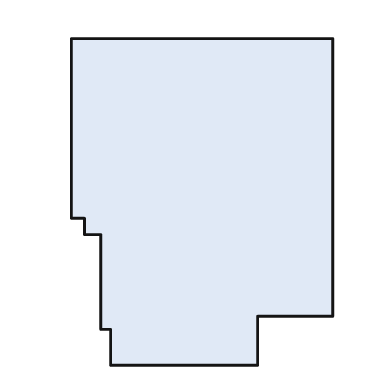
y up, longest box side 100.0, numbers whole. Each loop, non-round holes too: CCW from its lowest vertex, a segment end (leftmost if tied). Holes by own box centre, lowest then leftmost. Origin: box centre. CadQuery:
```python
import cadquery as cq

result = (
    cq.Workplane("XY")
    .moveTo(-28.0, -50.0)
    .lineTo(17.0, -50.0)
    .lineTo(17.0, -35.0)
    .lineTo(40.0, -35.0)
    .lineTo(40.0, 50.0)
    .lineTo(-40.0, 50.0)
    .lineTo(-40.0, -5.0)
    .lineTo(-36.0, -5.0)
    .lineTo(-36.0, -10.0)
    .lineTo(-31.0, -10.0)
    .lineTo(-31.0, -39.0)
    .lineTo(-28.0, -39.0)
    .close()
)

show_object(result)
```